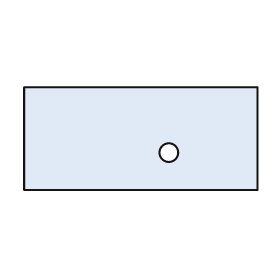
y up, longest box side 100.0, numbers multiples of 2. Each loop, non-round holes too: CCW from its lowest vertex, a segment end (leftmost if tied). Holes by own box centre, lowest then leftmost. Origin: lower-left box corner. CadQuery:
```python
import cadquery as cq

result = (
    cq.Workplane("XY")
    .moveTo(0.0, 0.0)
    .lineTo(100.0, 0.0)
    .lineTo(100.0, 44.0)
    .lineTo(0.0, 44.0)
    .close()
    .moveTo(62.0, 16.0)
    .circle(4.0)
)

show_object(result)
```